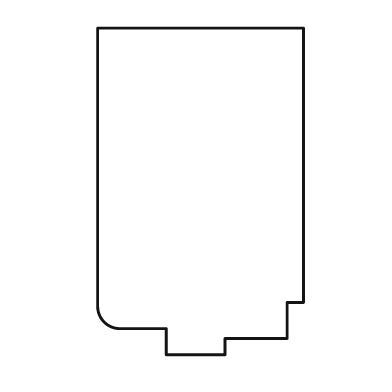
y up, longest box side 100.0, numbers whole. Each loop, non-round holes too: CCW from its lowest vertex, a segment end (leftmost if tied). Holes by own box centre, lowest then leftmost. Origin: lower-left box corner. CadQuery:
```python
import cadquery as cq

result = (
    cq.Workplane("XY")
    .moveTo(21.0, 0.0)
    .lineTo(39.0, 0.0)
    .lineTo(39.0, 5.0)
    .lineTo(58.0, 5.0)
    .lineTo(58.0, 16.0)
    .lineTo(63.0, 16.0)
    .lineTo(63.0, 100.0)
    .lineTo(0.0, 100.0)
    .lineTo(0.0, 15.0)
    .threePointArc((2.0, 10.0), (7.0, 8.0))
    .lineTo(21.0, 8.0)
    .close()
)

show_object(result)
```